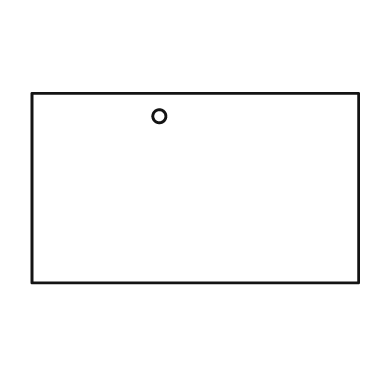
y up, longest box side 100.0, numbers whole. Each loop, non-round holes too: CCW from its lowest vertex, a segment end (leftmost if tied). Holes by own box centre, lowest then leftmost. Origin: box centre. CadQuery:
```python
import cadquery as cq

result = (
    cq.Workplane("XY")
    .moveTo(-50.0, -29.0)
    .lineTo(50.0, -29.0)
    .lineTo(50.0, 29.0)
    .lineTo(-50.0, 29.0)
    .close()
    .moveTo(-11.0, 22.0)
    .circle(2.0)
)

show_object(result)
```